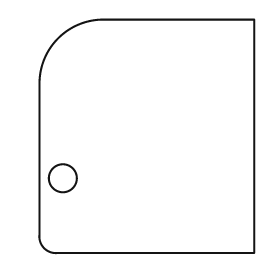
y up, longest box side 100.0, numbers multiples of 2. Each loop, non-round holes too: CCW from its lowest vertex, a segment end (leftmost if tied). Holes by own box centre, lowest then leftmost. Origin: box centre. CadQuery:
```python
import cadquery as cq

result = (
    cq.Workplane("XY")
    .moveTo(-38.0, -50.0)
    .lineTo(46.0, -50.0)
    .lineTo(46.0, 50.0)
    .lineTo(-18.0, 50.0)
    .threePointArc((-38.0, 42.0), (-46.0, 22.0))
    .lineTo(-46.0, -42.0)
    .threePointArc((-44.0, -48.0), (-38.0, -50.0))
    .close()
    .moveTo(-36.0, -18.0)
    .circle(6.0)
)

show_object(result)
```